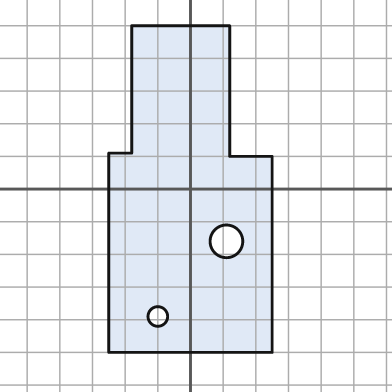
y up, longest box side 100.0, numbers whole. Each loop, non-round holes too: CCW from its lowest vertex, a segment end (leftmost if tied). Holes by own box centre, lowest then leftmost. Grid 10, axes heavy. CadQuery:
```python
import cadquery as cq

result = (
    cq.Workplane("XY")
    .moveTo(-25.0, -50.0)
    .lineTo(25.0, -50.0)
    .lineTo(25.0, 10.0)
    .lineTo(12.0, 10.0)
    .lineTo(12.0, 50.0)
    .lineTo(-18.0, 50.0)
    .lineTo(-18.0, 11.0)
    .lineTo(-25.0, 11.0)
    .close()
    .moveTo(-10.0, -39.0)
    .circle(3.0)
    .moveTo(11.0, -16.0)
    .circle(5.0)
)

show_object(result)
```